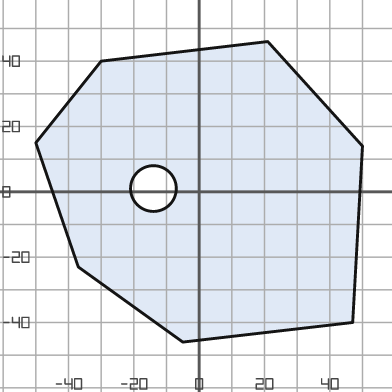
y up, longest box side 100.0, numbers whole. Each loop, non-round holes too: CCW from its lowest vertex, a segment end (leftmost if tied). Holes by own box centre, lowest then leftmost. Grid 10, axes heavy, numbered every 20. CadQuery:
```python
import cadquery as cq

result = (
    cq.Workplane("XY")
    .moveTo(-5.0, -46.0)
    .lineTo(47.0, -40.0)
    .lineTo(50.0, 14.0)
    .lineTo(21.0, 46.0)
    .lineTo(-30.0, 40.0)
    .lineTo(-50.0, 15.0)
    .lineTo(-37.0, -23.0)
    .close()
    .moveTo(-14.0, 1.0)
    .circle(7.0)
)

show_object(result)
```